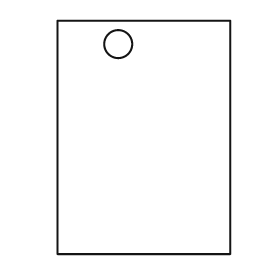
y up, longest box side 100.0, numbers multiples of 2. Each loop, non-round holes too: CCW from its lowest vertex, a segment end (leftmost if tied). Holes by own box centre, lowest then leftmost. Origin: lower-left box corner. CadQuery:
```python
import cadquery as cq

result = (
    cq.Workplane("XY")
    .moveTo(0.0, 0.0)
    .lineTo(74.0, 0.0)
    .lineTo(74.0, 100.0)
    .lineTo(0.0, 100.0)
    .close()
    .moveTo(26.0, 90.0)
    .circle(6.0)
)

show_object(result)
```